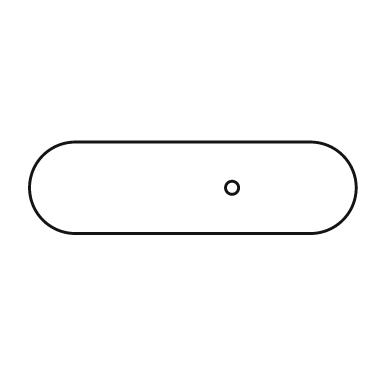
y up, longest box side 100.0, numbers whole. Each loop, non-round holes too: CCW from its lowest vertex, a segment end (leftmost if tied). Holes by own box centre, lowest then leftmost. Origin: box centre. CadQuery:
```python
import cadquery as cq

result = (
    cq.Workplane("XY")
    .moveTo(-36.0, -14.0)
    .lineTo(36.0, -14.0)
    .threePointArc((50.0, 0.0), (36.0, 14.0))
    .lineTo(-36.0, 14.0)
    .threePointArc((-50.0, 0.0), (-36.0, -14.0))
    .close()
    .moveTo(12.0, 0.0)
    .circle(2.0)
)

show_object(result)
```